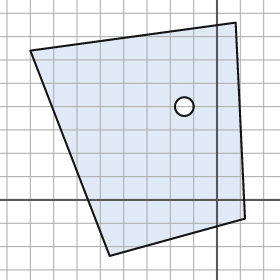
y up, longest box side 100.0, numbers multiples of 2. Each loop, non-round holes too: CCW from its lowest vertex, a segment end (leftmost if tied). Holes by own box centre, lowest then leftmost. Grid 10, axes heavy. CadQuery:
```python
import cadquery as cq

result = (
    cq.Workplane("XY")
    .moveTo(-46.0, -24.0)
    .lineTo(12.0, -8.0)
    .lineTo(8.0, 76.0)
    .lineTo(-80.0, 64.0)
    .close()
    .moveTo(-14.0, 40.0)
    .circle(4.0)
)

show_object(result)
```